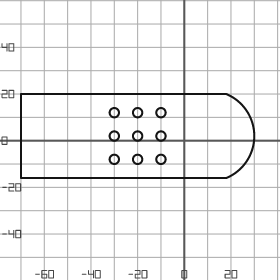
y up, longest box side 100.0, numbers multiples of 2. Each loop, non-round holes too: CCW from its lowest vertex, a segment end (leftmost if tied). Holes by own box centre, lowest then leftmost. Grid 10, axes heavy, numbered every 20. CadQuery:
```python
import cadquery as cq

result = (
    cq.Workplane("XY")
    .moveTo(-70.0, -16.0)
    .lineTo(18.0, -16.0)
    .threePointArc((30.0, 2.0), (18.0, 20.0))
    .lineTo(-70.0, 20.0)
    .close()
    .moveTo(-30.0, -8.0)
    .circle(2.0)
    .moveTo(-20.0, -8.0)
    .circle(2.0)
    .moveTo(-10.0, -8.0)
    .circle(2.0)
    .moveTo(-30.0, 2.0)
    .circle(2.0)
    .moveTo(-20.0, 2.0)
    .circle(2.0)
    .moveTo(-10.0, 2.0)
    .circle(2.0)
    .moveTo(-30.0, 12.0)
    .circle(2.0)
    .moveTo(-20.0, 12.0)
    .circle(2.0)
    .moveTo(-10.0, 12.0)
    .circle(2.0)
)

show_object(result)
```